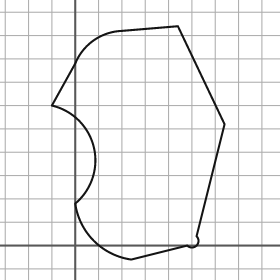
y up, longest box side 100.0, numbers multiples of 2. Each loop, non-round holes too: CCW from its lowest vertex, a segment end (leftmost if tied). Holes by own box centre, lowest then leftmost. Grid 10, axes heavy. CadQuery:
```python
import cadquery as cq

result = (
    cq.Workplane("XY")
    .moveTo(24.0, -6.0)
    .lineTo(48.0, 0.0)
    .threePointArc((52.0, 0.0), (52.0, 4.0))
    .lineTo(64.0, 52.0)
    .lineTo(44.0, 94.0)
    .lineTo(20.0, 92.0)
    .threePointArc((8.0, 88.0), (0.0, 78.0))
    .lineTo(-10.0, 60.0)
    .threePointArc((8.0, 42.0), (0.0, 18.0))
    .threePointArc((8.0, 2.0), (24.0, -6.0))
    .close()
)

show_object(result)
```